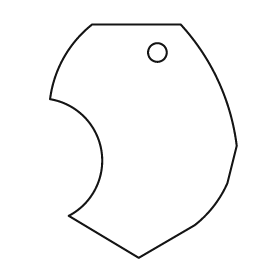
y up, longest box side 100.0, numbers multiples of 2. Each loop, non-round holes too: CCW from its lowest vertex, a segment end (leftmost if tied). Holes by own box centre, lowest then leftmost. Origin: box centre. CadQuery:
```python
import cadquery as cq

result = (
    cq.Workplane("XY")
    .moveTo(-2.0, -50.0)
    .lineTo(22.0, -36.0)
    .threePointArc((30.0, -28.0), (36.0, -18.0))
    .lineTo(40.0, -2.0)
    .threePointArc((32.0, 26.0), (16.0, 50.0))
    .lineTo(-22.0, 50.0)
    .threePointArc((-34.0, 36.0), (-40.0, 18.0))
    .threePointArc((-18.0, -4.0), (-32.0, -32.0))
    .close()
    .moveTo(6.0, 38.0)
    .circle(4.0)
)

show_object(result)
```